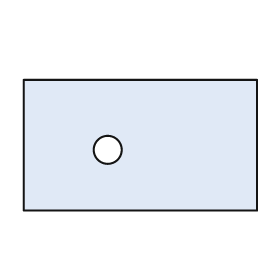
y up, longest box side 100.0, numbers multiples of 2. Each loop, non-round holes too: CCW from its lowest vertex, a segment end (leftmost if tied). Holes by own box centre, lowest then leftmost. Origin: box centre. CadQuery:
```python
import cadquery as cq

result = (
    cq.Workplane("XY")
    .moveTo(-50.0, -28.0)
    .lineTo(50.0, -28.0)
    .lineTo(50.0, 28.0)
    .lineTo(-50.0, 28.0)
    .close()
    .moveTo(-14.0, -2.0)
    .circle(6.0)
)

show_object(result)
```